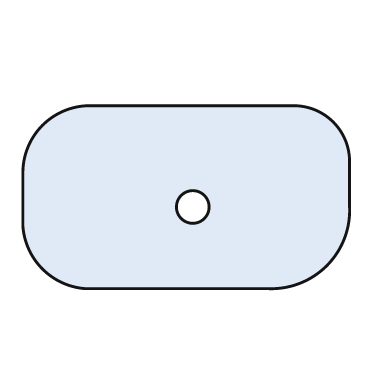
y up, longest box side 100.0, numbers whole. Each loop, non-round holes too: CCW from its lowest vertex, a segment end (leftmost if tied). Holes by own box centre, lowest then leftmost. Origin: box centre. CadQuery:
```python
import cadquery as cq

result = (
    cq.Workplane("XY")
    .moveTo(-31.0, -28.0)
    .lineTo(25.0, -28.0)
    .threePointArc((43.0, -21.0), (50.0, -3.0))
    .lineTo(50.0, 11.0)
    .threePointArc((45.0, 23.0), (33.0, 28.0))
    .lineTo(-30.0, 28.0)
    .threePointArc((-44.0, 22.0), (-50.0, 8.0))
    .lineTo(-50.0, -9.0)
    .threePointArc((-44.0, -22.0), (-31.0, -28.0))
    .close()
    .moveTo(2.0, -3.0)
    .circle(5.0)
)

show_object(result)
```